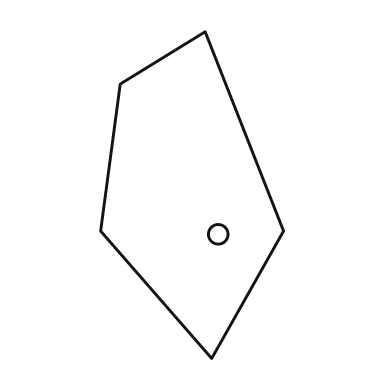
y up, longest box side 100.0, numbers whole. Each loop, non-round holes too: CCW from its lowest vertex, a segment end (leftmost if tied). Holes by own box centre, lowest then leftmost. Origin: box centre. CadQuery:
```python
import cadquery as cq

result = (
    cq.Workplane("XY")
    .moveTo(6.0, -50.0)
    .lineTo(28.0, -11.0)
    .lineTo(4.0, 50.0)
    .lineTo(-22.0, 34.0)
    .lineTo(-28.0, -11.0)
    .close()
    .moveTo(8.0, -12.0)
    .circle(3.0)
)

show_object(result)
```